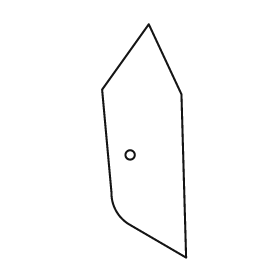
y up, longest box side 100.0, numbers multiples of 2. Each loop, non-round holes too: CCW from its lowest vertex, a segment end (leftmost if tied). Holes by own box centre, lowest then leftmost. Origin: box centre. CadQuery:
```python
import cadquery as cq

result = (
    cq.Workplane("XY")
    .moveTo(18.0, -50.0)
    .lineTo(16.0, 20.0)
    .lineTo(2.0, 50.0)
    .lineTo(-18.0, 22.0)
    .lineTo(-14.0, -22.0)
    .threePointArc((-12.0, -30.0), (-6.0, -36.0))
    .close()
    .moveTo(-6.0, -6.0)
    .circle(2.0)
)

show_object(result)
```